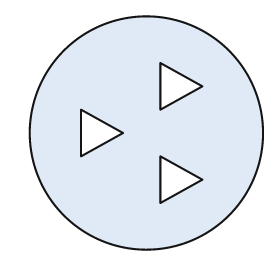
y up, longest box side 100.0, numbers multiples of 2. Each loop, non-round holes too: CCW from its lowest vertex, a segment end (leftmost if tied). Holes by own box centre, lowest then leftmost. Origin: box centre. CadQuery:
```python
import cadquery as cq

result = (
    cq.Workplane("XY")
    .moveTo(0.0, 0.0)
    .circle(50.0)
    .moveTo(6.0, -30.0)
    .lineTo(24.0, -20.0)
    .lineTo(6.0, -10.0)
    .close()
    .moveTo(-28.0, -10.0)
    .lineTo(-10.0, 0.0)
    .lineTo(-28.0, 10.0)
    .close()
    .moveTo(6.0, 10.0)
    .lineTo(24.0, 20.0)
    .lineTo(6.0, 30.0)
    .close()
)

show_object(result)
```